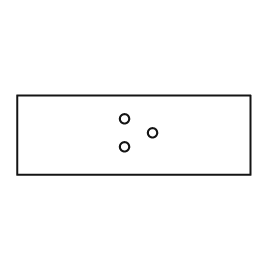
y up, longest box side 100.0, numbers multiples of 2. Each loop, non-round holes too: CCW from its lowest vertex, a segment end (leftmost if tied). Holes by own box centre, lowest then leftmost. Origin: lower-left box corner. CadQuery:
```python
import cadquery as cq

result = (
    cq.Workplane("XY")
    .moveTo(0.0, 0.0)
    .lineTo(100.0, 0.0)
    .lineTo(100.0, 34.0)
    .lineTo(0.0, 34.0)
    .close()
    .moveTo(46.0, 12.0)
    .circle(2.0)
    .moveTo(58.0, 18.0)
    .circle(2.0)
    .moveTo(46.0, 24.0)
    .circle(2.0)
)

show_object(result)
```